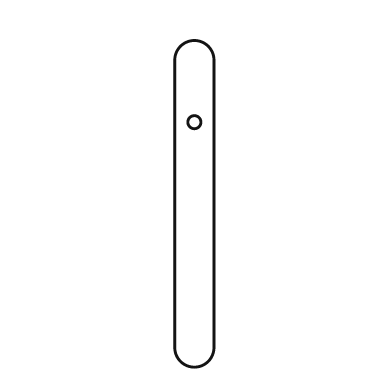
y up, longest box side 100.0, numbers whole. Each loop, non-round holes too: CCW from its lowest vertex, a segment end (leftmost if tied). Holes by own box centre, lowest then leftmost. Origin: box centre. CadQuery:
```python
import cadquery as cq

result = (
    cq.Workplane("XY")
    .moveTo(-6.0, -44.0)
    .threePointArc((0.0, -50.0), (6.0, -44.0))
    .lineTo(6.0, 44.0)
    .threePointArc((0.0, 50.0), (-6.0, 44.0))
    .close()
    .moveTo(0.0, 25.0)
    .circle(2.0)
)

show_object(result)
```